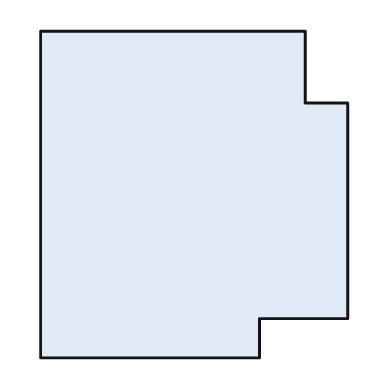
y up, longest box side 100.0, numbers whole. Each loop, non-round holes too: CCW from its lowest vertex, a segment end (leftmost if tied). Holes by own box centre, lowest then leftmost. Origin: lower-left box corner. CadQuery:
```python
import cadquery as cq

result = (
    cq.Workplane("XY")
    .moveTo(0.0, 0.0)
    .lineTo(67.0, 0.0)
    .lineTo(67.0, 12.0)
    .lineTo(94.0, 12.0)
    .lineTo(94.0, 78.0)
    .lineTo(81.0, 78.0)
    .lineTo(81.0, 100.0)
    .lineTo(0.0, 100.0)
    .close()
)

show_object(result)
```